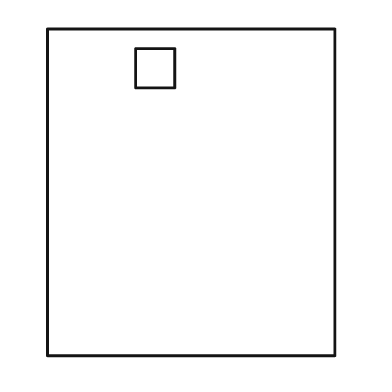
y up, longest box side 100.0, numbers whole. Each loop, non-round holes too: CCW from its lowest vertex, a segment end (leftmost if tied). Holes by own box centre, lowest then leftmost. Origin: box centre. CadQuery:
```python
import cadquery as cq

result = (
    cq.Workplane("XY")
    .moveTo(-44.0, -50.0)
    .lineTo(44.0, -50.0)
    .lineTo(44.0, 50.0)
    .lineTo(-44.0, 50.0)
    .close()
    .moveTo(-17.0, 32.0)
    .lineTo(-5.0, 32.0)
    .lineTo(-5.0, 44.0)
    .lineTo(-17.0, 44.0)
    .close()
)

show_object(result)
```